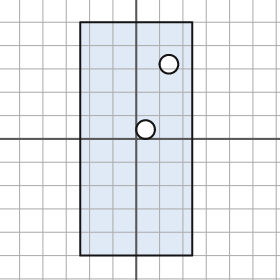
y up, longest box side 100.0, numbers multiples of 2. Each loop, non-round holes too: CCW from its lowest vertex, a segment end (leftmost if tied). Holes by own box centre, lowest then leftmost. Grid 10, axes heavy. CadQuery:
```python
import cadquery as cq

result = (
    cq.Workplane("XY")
    .moveTo(-24.0, -50.0)
    .lineTo(24.0, -50.0)
    .lineTo(24.0, 50.0)
    .lineTo(-24.0, 50.0)
    .close()
    .moveTo(4.0, 4.0)
    .circle(4.0)
    .moveTo(14.0, 32.0)
    .circle(4.0)
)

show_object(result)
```